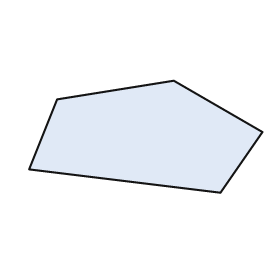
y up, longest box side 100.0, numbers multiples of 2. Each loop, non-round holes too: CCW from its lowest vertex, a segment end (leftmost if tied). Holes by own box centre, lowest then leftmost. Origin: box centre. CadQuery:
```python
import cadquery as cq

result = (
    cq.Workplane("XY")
    .moveTo(32.0, -24.0)
    .lineTo(50.0, 2.0)
    .lineTo(12.0, 24.0)
    .lineTo(-38.0, 16.0)
    .lineTo(-50.0, -14.0)
    .close()
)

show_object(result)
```